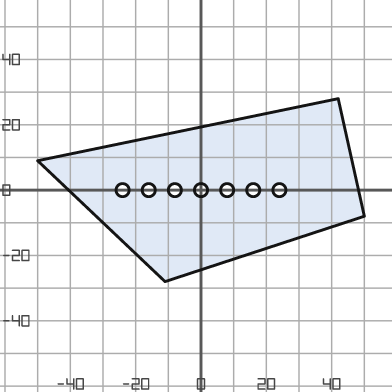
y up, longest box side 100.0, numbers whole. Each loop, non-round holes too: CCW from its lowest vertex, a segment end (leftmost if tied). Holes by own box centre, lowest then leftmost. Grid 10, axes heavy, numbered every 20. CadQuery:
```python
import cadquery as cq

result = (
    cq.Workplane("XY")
    .moveTo(-11.0, -28.0)
    .lineTo(50.0, -8.0)
    .lineTo(42.0, 28.0)
    .lineTo(-50.0, 9.0)
    .close()
    .moveTo(-24.0, 0.0)
    .circle(2.0)
    .moveTo(-16.0, 0.0)
    .circle(2.0)
    .moveTo(-8.0, 0.0)
    .circle(2.0)
    .moveTo(0.0, 0.0)
    .circle(2.0)
    .moveTo(8.0, 0.0)
    .circle(2.0)
    .moveTo(16.0, 0.0)
    .circle(2.0)
    .moveTo(24.0, 0.0)
    .circle(2.0)
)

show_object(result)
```